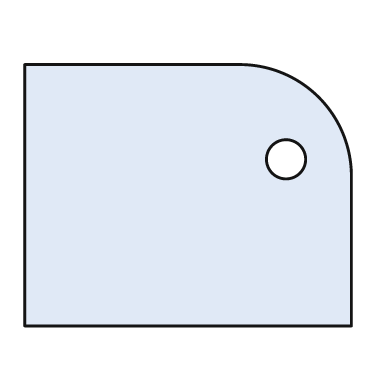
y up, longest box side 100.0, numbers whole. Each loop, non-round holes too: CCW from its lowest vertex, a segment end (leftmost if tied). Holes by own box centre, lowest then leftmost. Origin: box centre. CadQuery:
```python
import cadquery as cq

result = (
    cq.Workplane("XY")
    .moveTo(-50.0, -40.0)
    .lineTo(50.0, -40.0)
    .lineTo(50.0, 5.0)
    .threePointArc((40.0, 30.0), (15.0, 40.0))
    .lineTo(-50.0, 40.0)
    .close()
    .moveTo(30.0, 11.0)
    .circle(6.0)
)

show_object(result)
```